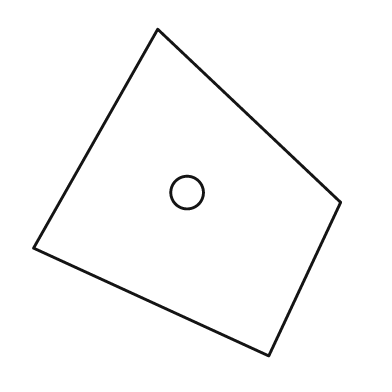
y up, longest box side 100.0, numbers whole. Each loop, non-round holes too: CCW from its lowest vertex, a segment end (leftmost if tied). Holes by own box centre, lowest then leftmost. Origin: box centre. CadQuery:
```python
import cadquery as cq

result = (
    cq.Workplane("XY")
    .moveTo(25.0, -50.0)
    .lineTo(47.0, -3.0)
    .lineTo(-9.0, 50.0)
    .lineTo(-47.0, -17.0)
    .close()
    .moveTo(0.0, 0.0)
    .circle(5.0)
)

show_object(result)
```